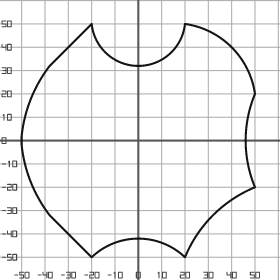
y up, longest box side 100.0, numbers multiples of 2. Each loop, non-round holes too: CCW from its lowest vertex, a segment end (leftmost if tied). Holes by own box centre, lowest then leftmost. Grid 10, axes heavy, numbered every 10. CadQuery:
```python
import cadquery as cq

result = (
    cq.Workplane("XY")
    .moveTo(-20.0, -50.0)
    .threePointArc((0.0, -42.0), (20.0, -50.0))
    .threePointArc((32.0, -32.0), (50.0, -20.0))
    .threePointArc((46.0, 0.0), (50.0, 20.0))
    .threePointArc((40.0, 40.0), (20.0, 50.0))
    .threePointArc((0.0, 32.0), (-20.0, 50.0))
    .lineTo(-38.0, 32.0)
    .threePointArc((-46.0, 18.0), (-50.0, 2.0))
    .lineTo(-50.0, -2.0)
    .threePointArc((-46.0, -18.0), (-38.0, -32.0))
    .close()
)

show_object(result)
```